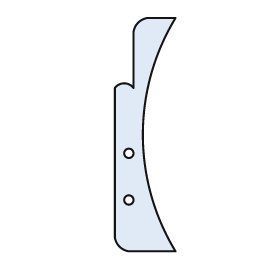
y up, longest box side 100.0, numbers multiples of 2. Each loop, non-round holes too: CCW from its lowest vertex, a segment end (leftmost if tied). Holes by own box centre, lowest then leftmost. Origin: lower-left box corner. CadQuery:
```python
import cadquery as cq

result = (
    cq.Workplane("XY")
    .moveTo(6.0, 0.0)
    .lineTo(26.0, 0.0)
    .threePointArc((12.0, 50.0), (26.0, 100.0))
    .lineTo(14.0, 100.0)
    .threePointArc((10.0, 98.0), (8.0, 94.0))
    .lineTo(8.0, 70.0)
    .threePointArc((4.0, 72.0), (0.0, 70.0))
    .lineTo(0.0, 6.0)
    .threePointArc((2.0, 2.0), (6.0, 0.0))
    .close()
    .moveTo(6.0, 22.0)
    .circle(2.0)
    .moveTo(6.0, 42.0)
    .circle(2.0)
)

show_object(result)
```